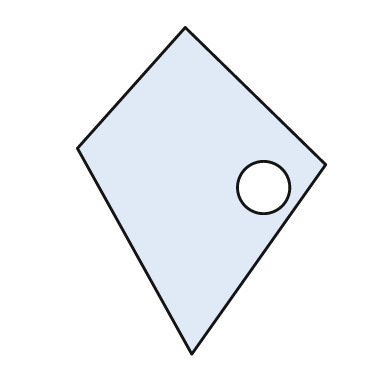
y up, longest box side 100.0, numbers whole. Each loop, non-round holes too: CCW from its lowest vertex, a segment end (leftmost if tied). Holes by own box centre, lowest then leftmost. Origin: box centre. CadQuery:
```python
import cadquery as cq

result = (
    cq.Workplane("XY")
    .moveTo(-3.0, -50.0)
    .lineTo(38.0, 8.0)
    .lineTo(-5.0, 50.0)
    .lineTo(-38.0, 13.0)
    .close()
    .moveTo(19.0, 1.0)
    .circle(8.0)
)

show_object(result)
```